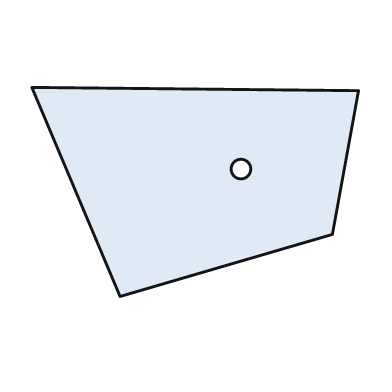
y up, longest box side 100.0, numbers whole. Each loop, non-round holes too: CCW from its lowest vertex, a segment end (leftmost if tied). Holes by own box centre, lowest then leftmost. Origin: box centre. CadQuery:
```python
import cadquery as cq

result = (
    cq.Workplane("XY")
    .moveTo(-23.0, -32.0)
    .lineTo(42.0, -13.0)
    .lineTo(50.0, 31.0)
    .lineTo(-50.0, 32.0)
    .close()
    .moveTo(14.0, 7.0)
    .circle(3.0)
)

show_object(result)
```